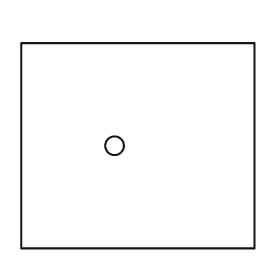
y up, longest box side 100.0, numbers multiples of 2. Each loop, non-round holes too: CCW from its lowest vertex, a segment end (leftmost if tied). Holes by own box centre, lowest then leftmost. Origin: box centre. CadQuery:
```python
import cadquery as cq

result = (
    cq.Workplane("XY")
    .moveTo(-50.0, -44.0)
    .lineTo(50.0, -44.0)
    .lineTo(50.0, 44.0)
    .lineTo(-50.0, 44.0)
    .close()
    .moveTo(-10.0, 0.0)
    .circle(4.0)
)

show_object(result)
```